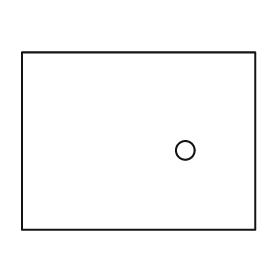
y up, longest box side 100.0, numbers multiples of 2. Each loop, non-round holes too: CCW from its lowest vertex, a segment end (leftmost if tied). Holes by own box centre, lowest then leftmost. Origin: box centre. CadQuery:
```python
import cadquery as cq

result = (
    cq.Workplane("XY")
    .moveTo(-50.0, -38.0)
    .lineTo(50.0, -38.0)
    .lineTo(50.0, 38.0)
    .lineTo(-50.0, 38.0)
    .close()
    .moveTo(20.0, -4.0)
    .circle(4.0)
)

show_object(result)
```